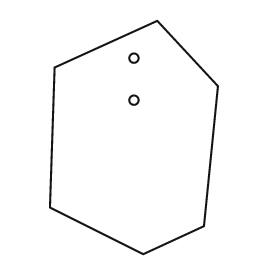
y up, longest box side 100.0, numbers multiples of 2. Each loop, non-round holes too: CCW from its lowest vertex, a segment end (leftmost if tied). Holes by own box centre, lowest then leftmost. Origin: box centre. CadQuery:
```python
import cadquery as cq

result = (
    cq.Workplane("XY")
    .moveTo(4.0, -50.0)
    .lineTo(30.0, -38.0)
    .lineTo(36.0, 22.0)
    .lineTo(10.0, 50.0)
    .lineTo(-34.0, 30.0)
    .lineTo(-36.0, -30.0)
    .close()
    .moveTo(0.0, 16.0)
    .circle(2.0)
    .moveTo(0.0, 34.0)
    .circle(2.0)
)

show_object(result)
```